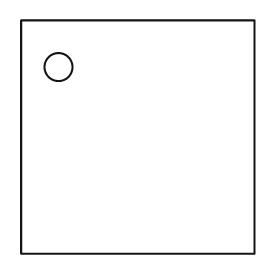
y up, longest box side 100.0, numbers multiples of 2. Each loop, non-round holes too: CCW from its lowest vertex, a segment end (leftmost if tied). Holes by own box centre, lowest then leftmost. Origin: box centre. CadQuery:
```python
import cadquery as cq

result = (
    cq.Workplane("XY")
    .moveTo(-50.0, -50.0)
    .lineTo(50.0, -50.0)
    .lineTo(50.0, 50.0)
    .lineTo(-50.0, 50.0)
    .close()
    .moveTo(-34.0, 30.0)
    .circle(6.0)
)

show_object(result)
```